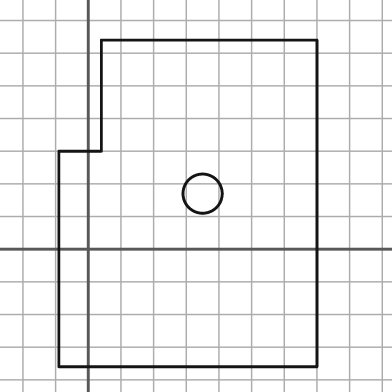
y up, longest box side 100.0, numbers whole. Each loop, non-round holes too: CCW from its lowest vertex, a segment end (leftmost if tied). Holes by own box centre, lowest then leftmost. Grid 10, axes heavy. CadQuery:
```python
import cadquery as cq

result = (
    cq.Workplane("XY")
    .moveTo(-9.0, -36.0)
    .lineTo(70.0, -36.0)
    .lineTo(70.0, 64.0)
    .lineTo(4.0, 64.0)
    .lineTo(4.0, 30.0)
    .lineTo(-9.0, 30.0)
    .close()
    .moveTo(35.0, 17.0)
    .circle(6.0)
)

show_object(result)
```